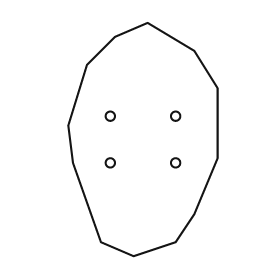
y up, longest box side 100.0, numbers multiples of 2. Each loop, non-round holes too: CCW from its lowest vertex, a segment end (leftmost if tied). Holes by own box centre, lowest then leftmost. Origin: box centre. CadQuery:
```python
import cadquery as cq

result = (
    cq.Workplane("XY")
    .moveTo(-4.0, -50.0)
    .lineTo(14.0, -44.0)
    .lineTo(22.0, -32.0)
    .lineTo(32.0, -8.0)
    .lineTo(32.0, 22.0)
    .lineTo(22.0, 38.0)
    .lineTo(2.0, 50.0)
    .lineTo(-12.0, 44.0)
    .lineTo(-24.0, 32.0)
    .lineTo(-32.0, 6.0)
    .lineTo(-30.0, -10.0)
    .lineTo(-18.0, -44.0)
    .close()
    .moveTo(-14.0, -10.0)
    .circle(2.0)
    .moveTo(14.0, -10.0)
    .circle(2.0)
    .moveTo(-14.0, 10.0)
    .circle(2.0)
    .moveTo(14.0, 10.0)
    .circle(2.0)
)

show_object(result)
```